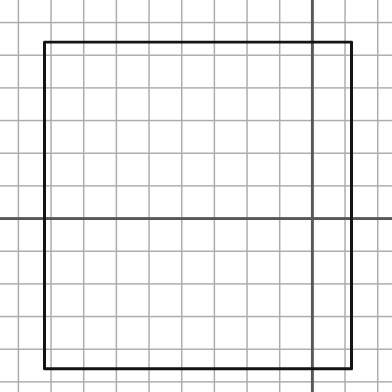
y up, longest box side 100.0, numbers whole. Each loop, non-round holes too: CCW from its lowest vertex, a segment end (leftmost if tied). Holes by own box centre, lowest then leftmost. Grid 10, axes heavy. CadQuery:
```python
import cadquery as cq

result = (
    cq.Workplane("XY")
    .moveTo(-82.0, -46.0)
    .lineTo(12.0, -46.0)
    .lineTo(12.0, 54.0)
    .lineTo(-82.0, 54.0)
    .close()
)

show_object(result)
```